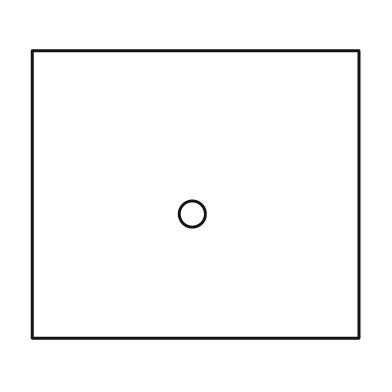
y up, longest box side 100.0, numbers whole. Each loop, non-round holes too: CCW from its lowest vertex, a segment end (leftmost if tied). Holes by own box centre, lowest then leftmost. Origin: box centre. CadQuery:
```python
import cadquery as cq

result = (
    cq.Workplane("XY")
    .moveTo(-50.0, -44.0)
    .lineTo(50.0, -44.0)
    .lineTo(50.0, 44.0)
    .lineTo(-50.0, 44.0)
    .close()
    .moveTo(-1.0, -6.0)
    .circle(4.0)
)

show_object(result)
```